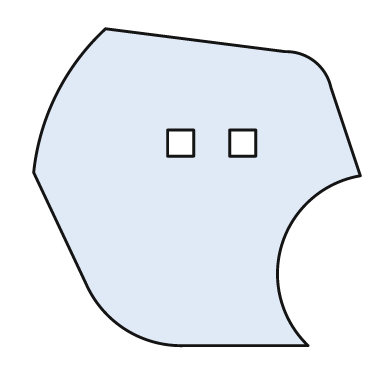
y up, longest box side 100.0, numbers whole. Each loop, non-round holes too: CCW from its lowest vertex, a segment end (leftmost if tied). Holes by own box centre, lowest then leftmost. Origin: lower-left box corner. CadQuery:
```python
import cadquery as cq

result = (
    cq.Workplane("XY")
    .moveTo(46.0, 0.0)
    .lineTo(84.0, 0.0)
    .threePointArc((76.0, 31.0), (100.0, 52.0))
    .lineTo(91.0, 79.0)
    .threePointArc((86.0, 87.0), (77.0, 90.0))
    .lineTo(22.0, 97.0)
    .threePointArc((7.0, 77.0), (0.0, 53.0))
    .lineTo(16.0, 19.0)
    .threePointArc((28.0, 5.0), (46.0, 0.0))
    .close()
    .moveTo(41.0, 58.0)
    .lineTo(49.0, 58.0)
    .lineTo(49.0, 66.0)
    .lineTo(41.0, 66.0)
    .close()
    .moveTo(60.0, 58.0)
    .lineTo(68.0, 58.0)
    .lineTo(68.0, 66.0)
    .lineTo(60.0, 66.0)
    .close()
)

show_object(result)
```